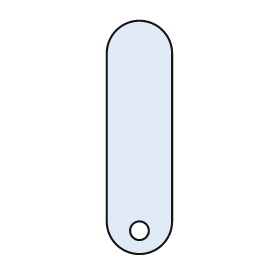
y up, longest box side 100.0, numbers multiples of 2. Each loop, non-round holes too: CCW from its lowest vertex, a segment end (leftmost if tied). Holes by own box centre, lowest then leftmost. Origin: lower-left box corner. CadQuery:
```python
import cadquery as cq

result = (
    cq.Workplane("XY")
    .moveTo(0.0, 14.0)
    .threePointArc((14.0, 0.0), (28.0, 14.0))
    .lineTo(28.0, 86.0)
    .threePointArc((14.0, 100.0), (0.0, 86.0))
    .close()
    .moveTo(14.0, 10.0)
    .circle(4.0)
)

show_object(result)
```